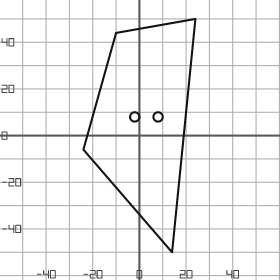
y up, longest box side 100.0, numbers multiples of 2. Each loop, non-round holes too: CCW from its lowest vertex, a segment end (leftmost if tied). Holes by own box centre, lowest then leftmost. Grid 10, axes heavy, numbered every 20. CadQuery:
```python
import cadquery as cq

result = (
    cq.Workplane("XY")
    .moveTo(14.0, -50.0)
    .lineTo(24.0, 50.0)
    .lineTo(-10.0, 44.0)
    .lineTo(-24.0, -6.0)
    .close()
    .moveTo(-2.0, 8.0)
    .circle(2.0)
    .moveTo(8.0, 8.0)
    .circle(2.0)
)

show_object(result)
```